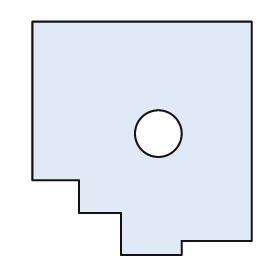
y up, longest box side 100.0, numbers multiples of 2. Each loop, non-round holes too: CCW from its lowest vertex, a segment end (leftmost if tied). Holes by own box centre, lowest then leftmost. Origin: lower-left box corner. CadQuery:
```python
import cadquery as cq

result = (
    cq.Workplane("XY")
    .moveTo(38.0, 0.0)
    .lineTo(64.0, 0.0)
    .lineTo(64.0, 6.0)
    .lineTo(94.0, 6.0)
    .lineTo(94.0, 100.0)
    .lineTo(0.0, 100.0)
    .lineTo(0.0, 32.0)
    .lineTo(20.0, 32.0)
    .lineTo(20.0, 18.0)
    .lineTo(38.0, 18.0)
    .close()
    .moveTo(54.0, 52.0)
    .circle(10.0)
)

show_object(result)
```